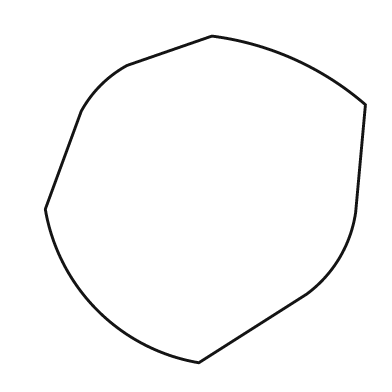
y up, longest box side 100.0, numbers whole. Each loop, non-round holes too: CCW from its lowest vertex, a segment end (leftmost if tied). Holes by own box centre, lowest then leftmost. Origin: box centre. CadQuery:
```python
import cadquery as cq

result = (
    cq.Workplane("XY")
    .moveTo(-2.0, -50.0)
    .lineTo(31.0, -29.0)
    .threePointArc((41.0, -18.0), (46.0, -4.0))
    .lineTo(49.0, 29.0)
    .threePointArc((27.0, 43.0), (2.0, 50.0))
    .lineTo(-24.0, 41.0)
    .threePointArc((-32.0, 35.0), (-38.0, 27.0))
    .lineTo(-49.0, -3.0)
    .threePointArc((-33.0, -34.0), (-2.0, -50.0))
    .close()
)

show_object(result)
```